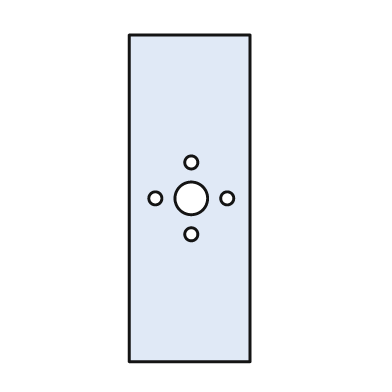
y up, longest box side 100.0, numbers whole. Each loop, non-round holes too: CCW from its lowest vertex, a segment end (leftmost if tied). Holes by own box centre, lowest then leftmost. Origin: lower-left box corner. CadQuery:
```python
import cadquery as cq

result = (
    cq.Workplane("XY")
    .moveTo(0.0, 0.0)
    .lineTo(37.0, 0.0)
    .lineTo(37.0, 100.0)
    .lineTo(0.0, 100.0)
    .close()
    .moveTo(19.0, 39.0)
    .circle(2.0)
    .moveTo(8.0, 50.0)
    .circle(2.0)
    .moveTo(19.0, 50.0)
    .circle(5.0)
    .moveTo(30.0, 50.0)
    .circle(2.0)
    .moveTo(19.0, 61.0)
    .circle(2.0)
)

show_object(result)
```